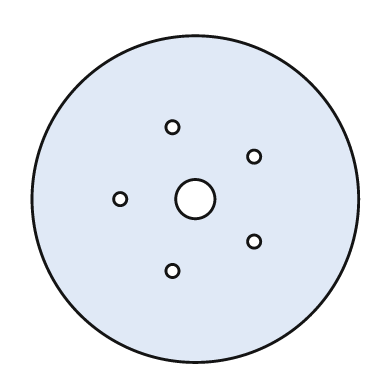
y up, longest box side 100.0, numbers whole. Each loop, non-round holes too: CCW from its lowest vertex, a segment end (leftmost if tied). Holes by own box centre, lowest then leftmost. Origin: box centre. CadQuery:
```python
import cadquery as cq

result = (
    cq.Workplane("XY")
    .moveTo(0.0, 0.0)
    .circle(50.0)
    .moveTo(-7.0, -22.0)
    .circle(2.0)
    .moveTo(18.0, -13.0)
    .circle(2.0)
    .moveTo(-23.0, 0.0)
    .circle(2.0)
    .moveTo(0.0, 0.0)
    .circle(6.0)
    .moveTo(18.0, 13.0)
    .circle(2.0)
    .moveTo(-7.0, 22.0)
    .circle(2.0)
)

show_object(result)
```